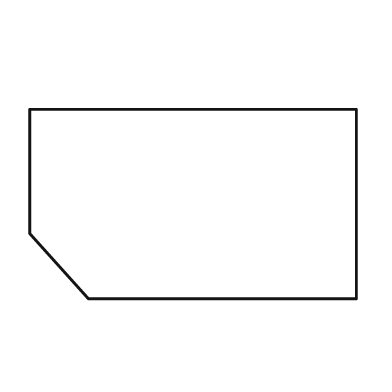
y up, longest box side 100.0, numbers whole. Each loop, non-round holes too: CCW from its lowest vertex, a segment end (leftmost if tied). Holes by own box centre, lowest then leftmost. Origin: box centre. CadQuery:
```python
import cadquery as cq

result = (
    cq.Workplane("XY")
    .moveTo(-32.0, -29.0)
    .lineTo(50.0, -29.0)
    .lineTo(50.0, 29.0)
    .lineTo(-50.0, 29.0)
    .lineTo(-50.0, -9.0)
    .close()
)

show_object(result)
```